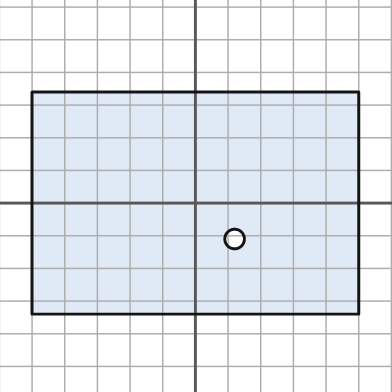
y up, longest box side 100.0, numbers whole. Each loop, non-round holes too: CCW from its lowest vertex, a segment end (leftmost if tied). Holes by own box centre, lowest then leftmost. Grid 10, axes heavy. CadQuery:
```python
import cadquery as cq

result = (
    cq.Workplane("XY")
    .moveTo(-50.0, -34.0)
    .lineTo(50.0, -34.0)
    .lineTo(50.0, 34.0)
    .lineTo(-50.0, 34.0)
    .close()
    .moveTo(12.0, -11.0)
    .circle(3.0)
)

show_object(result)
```